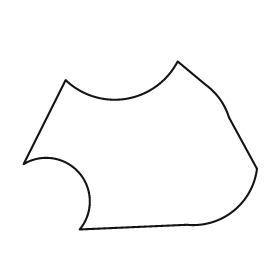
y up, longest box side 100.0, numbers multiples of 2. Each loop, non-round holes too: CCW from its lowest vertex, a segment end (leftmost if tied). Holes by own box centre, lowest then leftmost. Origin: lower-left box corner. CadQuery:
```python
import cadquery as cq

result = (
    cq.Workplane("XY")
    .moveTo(24.0, 0.0)
    .lineTo(70.0, 2.0)
    .threePointArc((90.0, 8.0), (100.0, 26.0))
    .lineTo(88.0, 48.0)
    .threePointArc((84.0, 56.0), (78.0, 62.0))
    .lineTo(66.0, 72.0)
    .threePointArc((44.0, 56.0), (18.0, 64.0))
    .lineTo(0.0, 28.0)
    .threePointArc((24.0, 24.0), (24.0, 0.0))
    .close()
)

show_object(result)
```